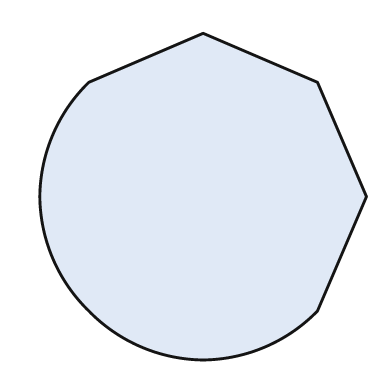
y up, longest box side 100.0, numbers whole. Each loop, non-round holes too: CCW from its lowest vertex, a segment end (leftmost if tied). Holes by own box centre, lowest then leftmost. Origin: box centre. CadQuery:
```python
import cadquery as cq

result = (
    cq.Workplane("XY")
    .moveTo(0.0, -50.0)
    .threePointArc((19.0, -46.0), (35.0, -35.0))
    .lineTo(50.0, 0.0)
    .lineTo(35.0, 35.0)
    .lineTo(0.0, 50.0)
    .lineTo(-35.0, 35.0)
    .threePointArc((-46.0, 19.0), (-50.0, 0.0))
    .threePointArc((-46.0, -19.0), (-35.0, -35.0))
    .threePointArc((-19.0, -46.0), (0.0, -50.0))
    .close()
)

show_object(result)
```